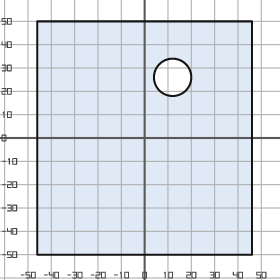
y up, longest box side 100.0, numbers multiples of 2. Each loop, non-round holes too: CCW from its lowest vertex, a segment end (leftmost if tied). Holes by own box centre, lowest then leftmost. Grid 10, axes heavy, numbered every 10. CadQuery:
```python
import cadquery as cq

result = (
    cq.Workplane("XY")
    .moveTo(-46.0, -50.0)
    .lineTo(46.0, -50.0)
    .lineTo(46.0, 50.0)
    .lineTo(-46.0, 50.0)
    .close()
    .moveTo(12.0, 26.0)
    .circle(8.0)
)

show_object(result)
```